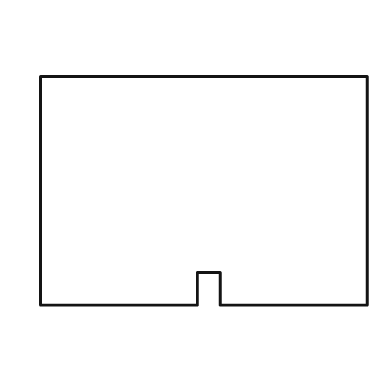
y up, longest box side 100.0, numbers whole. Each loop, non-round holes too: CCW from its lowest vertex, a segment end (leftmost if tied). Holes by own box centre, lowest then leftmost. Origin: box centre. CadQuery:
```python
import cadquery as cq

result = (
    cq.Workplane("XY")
    .moveTo(-50.0, -35.0)
    .lineTo(-2.0, -35.0)
    .lineTo(-2.0, -25.0)
    .lineTo(5.0, -25.0)
    .lineTo(5.0, -35.0)
    .lineTo(50.0, -35.0)
    .lineTo(50.0, 35.0)
    .lineTo(-50.0, 35.0)
    .close()
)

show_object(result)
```